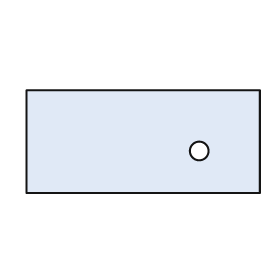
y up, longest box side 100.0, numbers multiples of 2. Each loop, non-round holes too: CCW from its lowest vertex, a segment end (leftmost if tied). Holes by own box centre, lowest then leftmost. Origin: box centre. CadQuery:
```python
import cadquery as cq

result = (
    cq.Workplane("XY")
    .moveTo(-50.0, -22.0)
    .lineTo(50.0, -22.0)
    .lineTo(50.0, 22.0)
    .lineTo(-50.0, 22.0)
    .close()
    .moveTo(24.0, -4.0)
    .circle(4.0)
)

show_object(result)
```